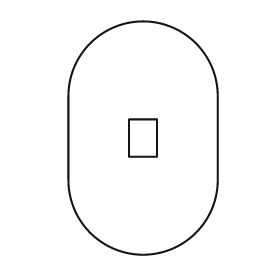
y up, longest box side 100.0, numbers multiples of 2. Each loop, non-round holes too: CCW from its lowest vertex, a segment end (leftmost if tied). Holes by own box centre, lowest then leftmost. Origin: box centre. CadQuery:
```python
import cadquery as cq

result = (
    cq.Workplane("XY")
    .moveTo(-32.0, -18.0)
    .threePointArc((0.0, -50.0), (32.0, -18.0))
    .lineTo(32.0, 18.0)
    .threePointArc((0.0, 50.0), (-32.0, 18.0))
    .close()
    .moveTo(-6.0, -8.0)
    .lineTo(6.0, -8.0)
    .lineTo(6.0, 8.0)
    .lineTo(-6.0, 8.0)
    .close()
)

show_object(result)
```